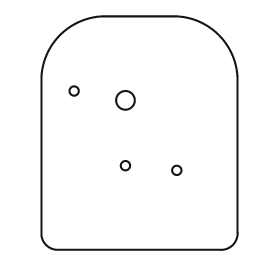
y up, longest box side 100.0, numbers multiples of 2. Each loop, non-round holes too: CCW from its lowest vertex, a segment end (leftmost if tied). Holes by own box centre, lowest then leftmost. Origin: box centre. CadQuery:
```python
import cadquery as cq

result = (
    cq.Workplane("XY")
    .moveTo(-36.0, -50.0)
    .lineTo(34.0, -50.0)
    .threePointArc((40.0, -48.0), (42.0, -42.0))
    .lineTo(42.0, 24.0)
    .threePointArc((34.0, 42.0), (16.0, 50.0))
    .lineTo(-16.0, 50.0)
    .threePointArc((-34.0, 42.0), (-42.0, 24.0))
    .lineTo(-42.0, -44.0)
    .threePointArc((-40.0, -48.0), (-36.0, -50.0))
    .close()
    .moveTo(16.0, -16.0)
    .circle(2.0)
    .moveTo(-6.0, -14.0)
    .circle(2.0)
    .moveTo(-6.0, 14.0)
    .circle(4.0)
    .moveTo(-28.0, 18.0)
    .circle(2.0)
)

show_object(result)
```